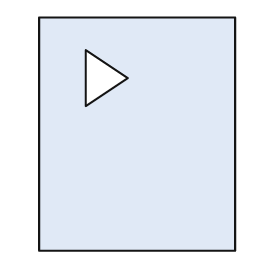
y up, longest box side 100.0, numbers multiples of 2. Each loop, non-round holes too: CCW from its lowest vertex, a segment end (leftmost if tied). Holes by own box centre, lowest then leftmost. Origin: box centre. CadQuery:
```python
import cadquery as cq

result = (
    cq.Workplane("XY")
    .moveTo(-42.0, -50.0)
    .lineTo(42.0, -50.0)
    .lineTo(42.0, 50.0)
    .lineTo(-42.0, 50.0)
    .close()
    .moveTo(-22.0, 12.0)
    .lineTo(-4.0, 24.0)
    .lineTo(-22.0, 36.0)
    .close()
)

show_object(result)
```